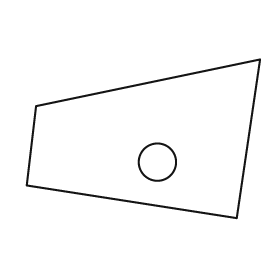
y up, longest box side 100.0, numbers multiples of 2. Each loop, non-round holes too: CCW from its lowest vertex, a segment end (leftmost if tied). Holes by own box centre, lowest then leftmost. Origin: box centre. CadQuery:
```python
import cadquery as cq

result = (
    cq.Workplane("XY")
    .moveTo(40.0, -34.0)
    .lineTo(50.0, 34.0)
    .lineTo(-46.0, 14.0)
    .lineTo(-50.0, -20.0)
    .close()
    .moveTo(6.0, -10.0)
    .circle(8.0)
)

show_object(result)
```